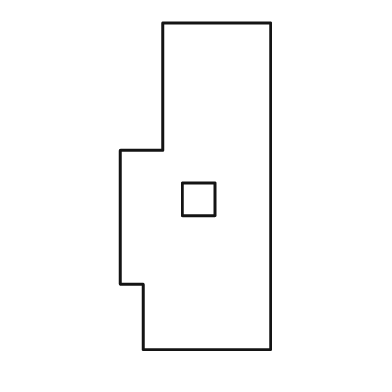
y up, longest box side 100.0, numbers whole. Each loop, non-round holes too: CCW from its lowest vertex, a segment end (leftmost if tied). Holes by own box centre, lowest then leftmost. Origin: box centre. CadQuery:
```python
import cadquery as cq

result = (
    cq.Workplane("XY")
    .moveTo(-16.0, -50.0)
    .lineTo(23.0, -50.0)
    .lineTo(23.0, 50.0)
    .lineTo(-10.0, 50.0)
    .lineTo(-10.0, 11.0)
    .lineTo(-23.0, 11.0)
    .lineTo(-23.0, -30.0)
    .lineTo(-16.0, -30.0)
    .close()
    .moveTo(-4.0, -9.0)
    .lineTo(6.0, -9.0)
    .lineTo(6.0, 1.0)
    .lineTo(-4.0, 1.0)
    .close()
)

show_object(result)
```